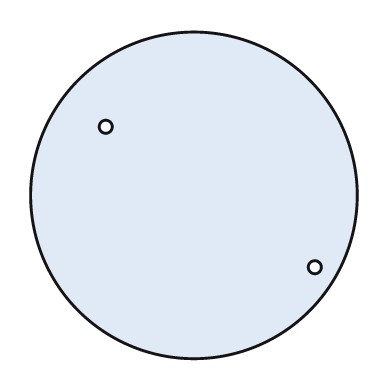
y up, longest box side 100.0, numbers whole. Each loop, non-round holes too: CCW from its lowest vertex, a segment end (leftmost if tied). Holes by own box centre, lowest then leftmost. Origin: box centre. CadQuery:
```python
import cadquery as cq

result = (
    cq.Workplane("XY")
    .moveTo(0.0, 0.0)
    .circle(50.0)
    .moveTo(37.0, -22.0)
    .circle(2.0)
    .moveTo(-27.0, 21.0)
    .circle(2.0)
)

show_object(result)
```